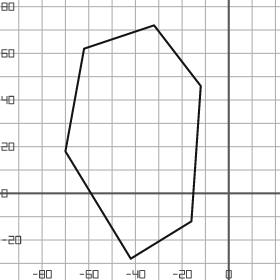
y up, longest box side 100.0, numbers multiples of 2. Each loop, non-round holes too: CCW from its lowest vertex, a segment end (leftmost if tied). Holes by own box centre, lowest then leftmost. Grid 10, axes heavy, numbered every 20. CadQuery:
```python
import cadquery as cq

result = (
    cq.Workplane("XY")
    .moveTo(-42.0, -28.0)
    .lineTo(-16.0, -12.0)
    .lineTo(-12.0, 46.0)
    .lineTo(-32.0, 72.0)
    .lineTo(-62.0, 62.0)
    .lineTo(-70.0, 18.0)
    .close()
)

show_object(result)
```